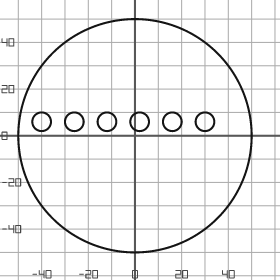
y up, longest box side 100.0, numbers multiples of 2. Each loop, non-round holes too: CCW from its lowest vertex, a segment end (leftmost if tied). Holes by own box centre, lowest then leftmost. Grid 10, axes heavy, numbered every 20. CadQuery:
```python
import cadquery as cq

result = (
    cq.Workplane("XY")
    .moveTo(0.0, 0.0)
    .circle(50.0)
    .moveTo(-40.0, 6.0)
    .circle(4.0)
    .moveTo(-26.0, 6.0)
    .circle(4.0)
    .moveTo(-12.0, 6.0)
    .circle(4.0)
    .moveTo(2.0, 6.0)
    .circle(4.0)
    .moveTo(16.0, 6.0)
    .circle(4.0)
    .moveTo(30.0, 6.0)
    .circle(4.0)
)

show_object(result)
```